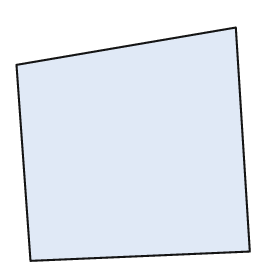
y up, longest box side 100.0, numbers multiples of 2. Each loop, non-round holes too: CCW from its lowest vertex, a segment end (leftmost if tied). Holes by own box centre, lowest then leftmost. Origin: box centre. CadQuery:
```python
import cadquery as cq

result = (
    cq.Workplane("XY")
    .moveTo(-44.0, -50.0)
    .lineTo(50.0, -46.0)
    .lineTo(44.0, 50.0)
    .lineTo(-50.0, 34.0)
    .close()
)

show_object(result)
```